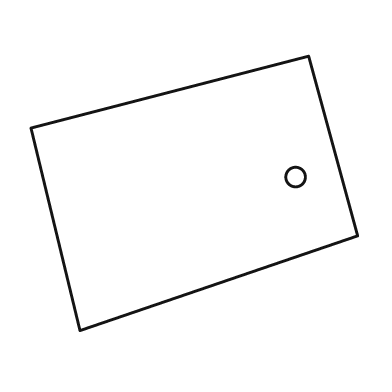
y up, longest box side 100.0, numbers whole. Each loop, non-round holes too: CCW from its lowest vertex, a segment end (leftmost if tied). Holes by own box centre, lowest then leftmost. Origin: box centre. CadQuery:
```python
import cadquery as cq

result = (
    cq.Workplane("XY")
    .moveTo(-35.0, -42.0)
    .lineTo(50.0, -13.0)
    .lineTo(35.0, 42.0)
    .lineTo(-50.0, 20.0)
    .close()
    .moveTo(31.0, 5.0)
    .circle(3.0)
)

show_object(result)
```